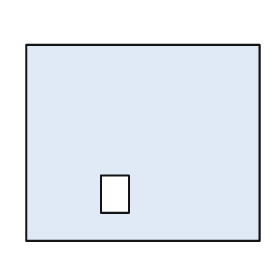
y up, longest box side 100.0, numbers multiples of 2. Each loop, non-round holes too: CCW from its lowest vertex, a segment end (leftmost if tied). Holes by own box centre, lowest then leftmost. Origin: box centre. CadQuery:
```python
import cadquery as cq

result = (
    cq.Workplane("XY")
    .moveTo(-50.0, -42.0)
    .lineTo(50.0, -42.0)
    .lineTo(50.0, 42.0)
    .lineTo(-50.0, 42.0)
    .close()
    .moveTo(-18.0, -30.0)
    .lineTo(-6.0, -30.0)
    .lineTo(-6.0, -14.0)
    .lineTo(-18.0, -14.0)
    .close()
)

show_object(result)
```